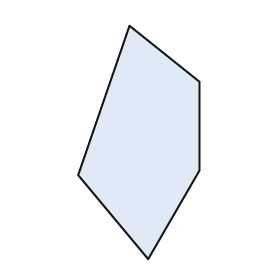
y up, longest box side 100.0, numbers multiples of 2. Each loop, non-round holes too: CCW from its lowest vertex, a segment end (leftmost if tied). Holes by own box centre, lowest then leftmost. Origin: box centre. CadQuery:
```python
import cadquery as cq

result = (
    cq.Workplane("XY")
    .moveTo(4.0, -50.0)
    .lineTo(26.0, -12.0)
    .lineTo(26.0, 26.0)
    .lineTo(-4.0, 50.0)
    .lineTo(-26.0, -14.0)
    .close()
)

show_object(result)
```